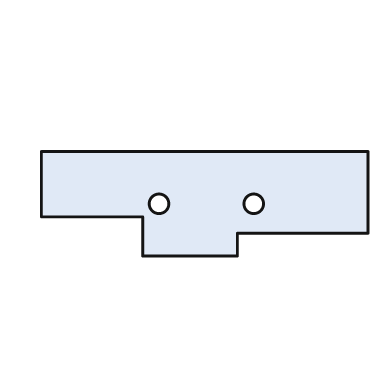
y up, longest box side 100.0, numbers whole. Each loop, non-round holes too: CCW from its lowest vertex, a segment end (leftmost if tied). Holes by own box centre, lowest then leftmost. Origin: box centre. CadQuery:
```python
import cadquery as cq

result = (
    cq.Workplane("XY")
    .moveTo(-19.0, -16.0)
    .lineTo(10.0, -16.0)
    .lineTo(10.0, -9.0)
    .lineTo(50.0, -9.0)
    .lineTo(50.0, 16.0)
    .lineTo(-50.0, 16.0)
    .lineTo(-50.0, -4.0)
    .lineTo(-19.0, -4.0)
    .close()
    .moveTo(-14.0, 0.0)
    .circle(3.0)
    .moveTo(15.0, 0.0)
    .circle(3.0)
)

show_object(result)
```